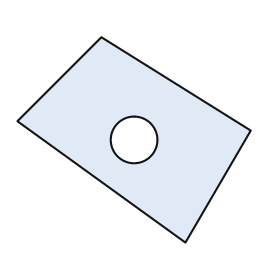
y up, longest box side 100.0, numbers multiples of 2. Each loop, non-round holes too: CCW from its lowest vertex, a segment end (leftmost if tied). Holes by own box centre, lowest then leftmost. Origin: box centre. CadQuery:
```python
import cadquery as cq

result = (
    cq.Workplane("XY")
    .moveTo(22.0, -44.0)
    .lineTo(50.0, 4.0)
    .lineTo(-14.0, 44.0)
    .lineTo(-50.0, 8.0)
    .close()
    .moveTo(0.0, 0.0)
    .circle(10.0)
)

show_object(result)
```